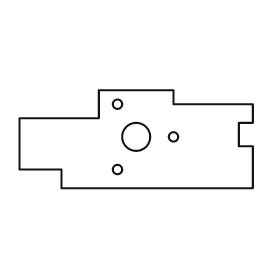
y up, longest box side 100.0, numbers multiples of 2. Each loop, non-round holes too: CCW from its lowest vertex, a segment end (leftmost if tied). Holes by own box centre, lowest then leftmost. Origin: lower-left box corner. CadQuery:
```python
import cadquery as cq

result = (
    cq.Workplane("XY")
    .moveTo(18.0, 0.0)
    .lineTo(100.0, 0.0)
    .lineTo(100.0, 18.0)
    .lineTo(94.0, 18.0)
    .lineTo(94.0, 28.0)
    .lineTo(100.0, 28.0)
    .lineTo(100.0, 36.0)
    .lineTo(66.0, 36.0)
    .lineTo(66.0, 42.0)
    .lineTo(34.0, 42.0)
    .lineTo(34.0, 30.0)
    .lineTo(0.0, 30.0)
    .lineTo(0.0, 8.0)
    .lineTo(18.0, 8.0)
    .close()
    .moveTo(42.0, 8.0)
    .circle(2.0)
    .moveTo(50.0, 22.0)
    .circle(6.0)
    .moveTo(66.0, 22.0)
    .circle(2.0)
    .moveTo(42.0, 36.0)
    .circle(2.0)
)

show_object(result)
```